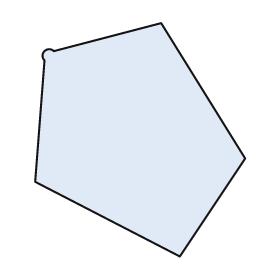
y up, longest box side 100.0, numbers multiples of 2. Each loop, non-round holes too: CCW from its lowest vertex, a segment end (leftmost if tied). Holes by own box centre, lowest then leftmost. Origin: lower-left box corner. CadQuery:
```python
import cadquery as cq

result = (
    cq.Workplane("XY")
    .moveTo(62.0, 0.0)
    .lineTo(90.0, 42.0)
    .lineTo(54.0, 100.0)
    .lineTo(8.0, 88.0)
    .threePointArc((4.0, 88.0), (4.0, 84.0))
    .lineTo(0.0, 32.0)
    .close()
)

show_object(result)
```